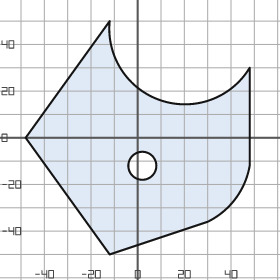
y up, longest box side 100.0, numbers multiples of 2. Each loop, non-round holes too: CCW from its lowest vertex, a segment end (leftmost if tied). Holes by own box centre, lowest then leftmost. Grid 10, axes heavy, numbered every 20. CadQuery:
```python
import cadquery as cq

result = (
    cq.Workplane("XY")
    .moveTo(-12.0, -50.0)
    .lineTo(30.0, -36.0)
    .threePointArc((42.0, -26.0), (48.0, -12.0))
    .lineTo(48.0, 30.0)
    .threePointArc((10.0, 16.0), (-12.0, 50.0))
    .lineTo(-48.0, 0.0)
    .close()
    .moveTo(2.0, -12.0)
    .circle(6.0)
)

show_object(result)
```